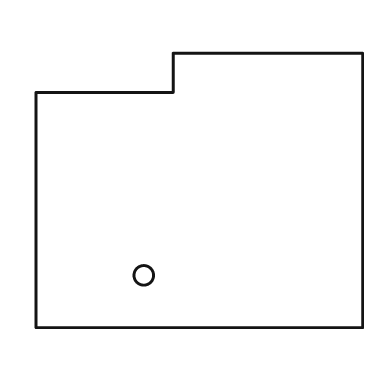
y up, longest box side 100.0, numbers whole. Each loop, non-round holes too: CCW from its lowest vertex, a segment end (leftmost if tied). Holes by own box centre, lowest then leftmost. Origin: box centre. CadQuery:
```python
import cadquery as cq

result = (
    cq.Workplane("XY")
    .moveTo(-50.0, -42.0)
    .lineTo(50.0, -42.0)
    .lineTo(50.0, 42.0)
    .lineTo(-8.0, 42.0)
    .lineTo(-8.0, 30.0)
    .lineTo(-50.0, 30.0)
    .close()
    .moveTo(-17.0, -26.0)
    .circle(3.0)
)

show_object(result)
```